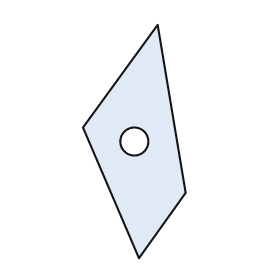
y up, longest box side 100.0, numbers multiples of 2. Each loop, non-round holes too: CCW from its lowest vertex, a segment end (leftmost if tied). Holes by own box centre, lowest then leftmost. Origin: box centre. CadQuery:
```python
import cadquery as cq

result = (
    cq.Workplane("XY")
    .moveTo(2.0, -50.0)
    .lineTo(22.0, -22.0)
    .lineTo(10.0, 50.0)
    .lineTo(-22.0, 6.0)
    .close()
    .moveTo(0.0, 0.0)
    .circle(6.0)
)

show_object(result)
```